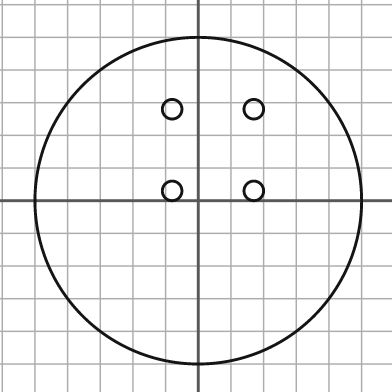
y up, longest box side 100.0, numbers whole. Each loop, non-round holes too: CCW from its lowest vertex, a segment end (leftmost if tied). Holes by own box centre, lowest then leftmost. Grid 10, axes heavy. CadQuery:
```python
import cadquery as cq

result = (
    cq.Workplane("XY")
    .moveTo(0.0, 0.0)
    .circle(50.0)
    .moveTo(-8.0, 3.0)
    .circle(3.0)
    .moveTo(17.0, 3.0)
    .circle(3.0)
    .moveTo(-8.0, 28.0)
    .circle(3.0)
    .moveTo(17.0, 28.0)
    .circle(3.0)
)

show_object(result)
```